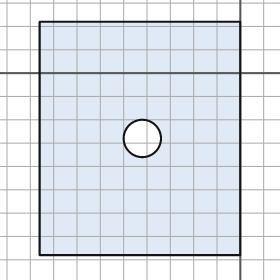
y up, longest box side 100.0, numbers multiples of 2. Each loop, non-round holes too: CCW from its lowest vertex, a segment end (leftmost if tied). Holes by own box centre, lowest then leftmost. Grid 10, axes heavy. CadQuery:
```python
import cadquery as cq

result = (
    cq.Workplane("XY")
    .moveTo(-86.0, -78.0)
    .lineTo(0.0, -78.0)
    .lineTo(0.0, 22.0)
    .lineTo(-86.0, 22.0)
    .close()
    .moveTo(-42.0, -28.0)
    .circle(8.0)
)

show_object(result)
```